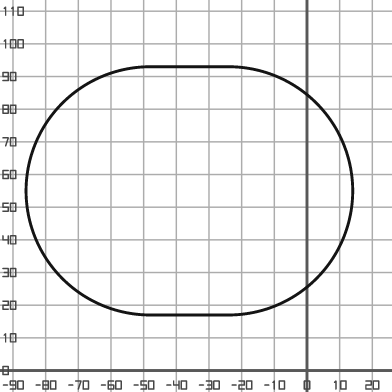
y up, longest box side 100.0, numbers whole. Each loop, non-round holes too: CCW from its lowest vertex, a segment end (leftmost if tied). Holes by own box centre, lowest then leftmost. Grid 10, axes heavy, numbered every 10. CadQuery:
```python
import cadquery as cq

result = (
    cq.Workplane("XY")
    .moveTo(-48.0, 17.0)
    .lineTo(-24.0, 17.0)
    .threePointArc((14.0, 55.0), (-24.0, 93.0))
    .lineTo(-48.0, 93.0)
    .threePointArc((-86.0, 55.0), (-48.0, 17.0))
    .close()
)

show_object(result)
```